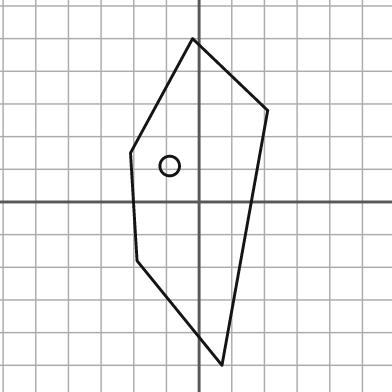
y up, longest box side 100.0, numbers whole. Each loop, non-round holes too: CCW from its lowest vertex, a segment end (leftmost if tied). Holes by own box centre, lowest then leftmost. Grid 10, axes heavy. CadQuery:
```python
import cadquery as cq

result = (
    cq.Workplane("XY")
    .moveTo(7.0, -50.0)
    .lineTo(21.0, 28.0)
    .lineTo(-2.0, 50.0)
    .lineTo(-21.0, 15.0)
    .lineTo(-19.0, -18.0)
    .close()
    .moveTo(-9.0, 11.0)
    .circle(3.0)
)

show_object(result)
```